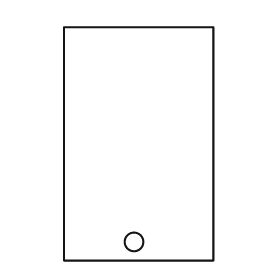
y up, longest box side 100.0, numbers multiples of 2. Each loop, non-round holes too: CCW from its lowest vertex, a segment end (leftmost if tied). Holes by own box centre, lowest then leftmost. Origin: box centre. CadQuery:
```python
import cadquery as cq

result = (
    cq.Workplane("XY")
    .moveTo(-32.0, -50.0)
    .lineTo(32.0, -50.0)
    .lineTo(32.0, 50.0)
    .lineTo(-32.0, 50.0)
    .close()
    .moveTo(-2.0, -42.0)
    .circle(4.0)
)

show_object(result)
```